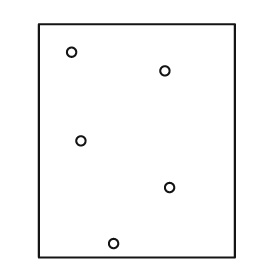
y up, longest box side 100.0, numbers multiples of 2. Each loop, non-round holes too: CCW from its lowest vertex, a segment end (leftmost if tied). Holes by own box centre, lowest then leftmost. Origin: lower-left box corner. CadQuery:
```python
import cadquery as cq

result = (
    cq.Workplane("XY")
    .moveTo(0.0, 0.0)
    .lineTo(84.0, 0.0)
    .lineTo(84.0, 100.0)
    .lineTo(0.0, 100.0)
    .close()
    .moveTo(32.0, 6.0)
    .circle(2.0)
    .moveTo(56.0, 30.0)
    .circle(2.0)
    .moveTo(18.0, 50.0)
    .circle(2.0)
    .moveTo(54.0, 80.0)
    .circle(2.0)
    .moveTo(14.0, 88.0)
    .circle(2.0)
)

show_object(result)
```